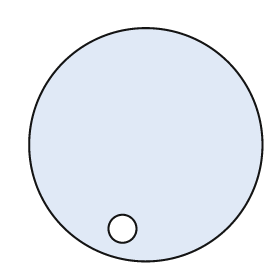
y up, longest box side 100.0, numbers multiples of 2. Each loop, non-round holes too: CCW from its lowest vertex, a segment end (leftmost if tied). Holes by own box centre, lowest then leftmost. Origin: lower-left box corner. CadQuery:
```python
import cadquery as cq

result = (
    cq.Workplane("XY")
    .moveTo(50.0, 50.0)
    .circle(50.0)
    .moveTo(40.0, 14.0)
    .circle(6.0)
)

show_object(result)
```